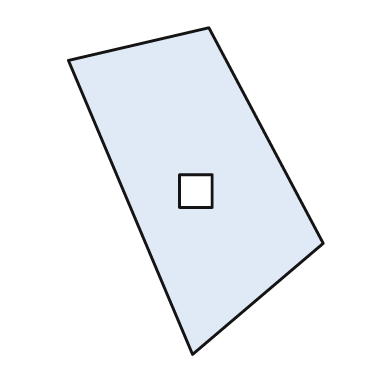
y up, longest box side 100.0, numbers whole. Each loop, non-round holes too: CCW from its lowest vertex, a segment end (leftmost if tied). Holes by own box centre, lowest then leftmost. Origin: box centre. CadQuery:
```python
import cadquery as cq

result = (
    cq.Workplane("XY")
    .moveTo(-1.0, -50.0)
    .lineTo(39.0, -16.0)
    .lineTo(4.0, 50.0)
    .lineTo(-39.0, 40.0)
    .close()
    .moveTo(-5.0, -5.0)
    .lineTo(5.0, -5.0)
    .lineTo(5.0, 5.0)
    .lineTo(-5.0, 5.0)
    .close()
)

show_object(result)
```